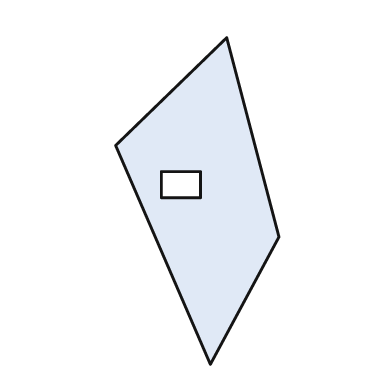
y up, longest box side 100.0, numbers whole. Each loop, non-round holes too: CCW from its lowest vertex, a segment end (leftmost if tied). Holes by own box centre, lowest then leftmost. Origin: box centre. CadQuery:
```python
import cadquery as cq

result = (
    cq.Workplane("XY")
    .moveTo(4.0, -50.0)
    .lineTo(25.0, -11.0)
    .lineTo(9.0, 50.0)
    .lineTo(-25.0, 17.0)
    .close()
    .moveTo(-11.0, 1.0)
    .lineTo(1.0, 1.0)
    .lineTo(1.0, 9.0)
    .lineTo(-11.0, 9.0)
    .close()
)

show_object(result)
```